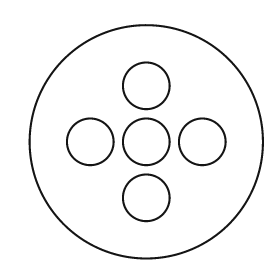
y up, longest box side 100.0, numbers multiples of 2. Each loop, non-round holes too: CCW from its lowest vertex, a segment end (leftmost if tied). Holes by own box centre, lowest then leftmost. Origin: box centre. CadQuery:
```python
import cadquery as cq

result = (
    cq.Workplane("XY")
    .moveTo(0.0, 0.0)
    .circle(50.0)
    .moveTo(0.0, -24.0)
    .circle(10.0)
    .moveTo(-24.0, 0.0)
    .circle(10.0)
    .moveTo(0.0, 0.0)
    .circle(10.0)
    .moveTo(24.0, 0.0)
    .circle(10.0)
    .moveTo(0.0, 24.0)
    .circle(10.0)
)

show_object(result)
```